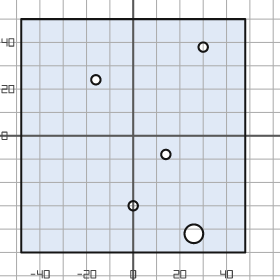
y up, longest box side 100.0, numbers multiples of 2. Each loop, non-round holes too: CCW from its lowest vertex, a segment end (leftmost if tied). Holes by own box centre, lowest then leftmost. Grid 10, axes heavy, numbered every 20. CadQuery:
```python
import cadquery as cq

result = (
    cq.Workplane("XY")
    .moveTo(-48.0, -50.0)
    .lineTo(48.0, -50.0)
    .lineTo(48.0, 50.0)
    .lineTo(-48.0, 50.0)
    .close()
    .moveTo(26.0, -42.0)
    .circle(4.0)
    .moveTo(0.0, -30.0)
    .circle(2.0)
    .moveTo(14.0, -8.0)
    .circle(2.0)
    .moveTo(-16.0, 24.0)
    .circle(2.0)
    .moveTo(30.0, 38.0)
    .circle(2.0)
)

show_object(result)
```